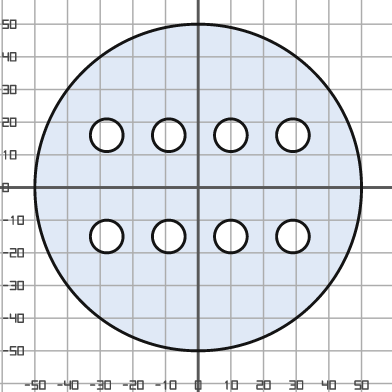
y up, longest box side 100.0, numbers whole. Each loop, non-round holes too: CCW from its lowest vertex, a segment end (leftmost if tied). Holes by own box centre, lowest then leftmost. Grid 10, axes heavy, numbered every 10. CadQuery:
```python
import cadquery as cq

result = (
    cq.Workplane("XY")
    .moveTo(0.0, 0.0)
    .circle(50.0)
    .moveTo(-28.0, -15.0)
    .circle(5.0)
    .moveTo(-9.0, -15.0)
    .circle(5.0)
    .moveTo(10.0, -15.0)
    .circle(5.0)
    .moveTo(29.0, -15.0)
    .circle(5.0)
    .moveTo(-28.0, 16.0)
    .circle(5.0)
    .moveTo(-9.0, 16.0)
    .circle(5.0)
    .moveTo(10.0, 16.0)
    .circle(5.0)
    .moveTo(29.0, 16.0)
    .circle(5.0)
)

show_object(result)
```